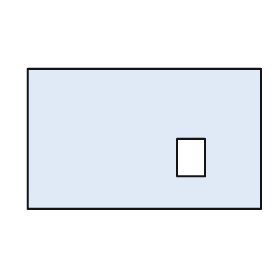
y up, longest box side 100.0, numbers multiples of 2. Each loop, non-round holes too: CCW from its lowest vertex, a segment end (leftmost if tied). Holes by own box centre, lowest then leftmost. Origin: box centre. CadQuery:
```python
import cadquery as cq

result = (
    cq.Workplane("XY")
    .moveTo(-50.0, -30.0)
    .lineTo(50.0, -30.0)
    .lineTo(50.0, 30.0)
    .lineTo(-50.0, 30.0)
    .close()
    .moveTo(14.0, -16.0)
    .lineTo(26.0, -16.0)
    .lineTo(26.0, 0.0)
    .lineTo(14.0, 0.0)
    .close()
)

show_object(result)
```